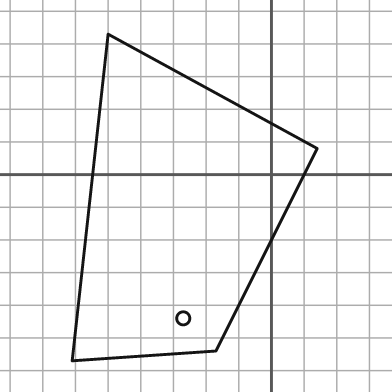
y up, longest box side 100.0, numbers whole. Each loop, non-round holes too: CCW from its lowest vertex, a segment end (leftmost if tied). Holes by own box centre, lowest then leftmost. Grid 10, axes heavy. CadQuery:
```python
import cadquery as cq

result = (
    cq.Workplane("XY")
    .moveTo(-61.0, -57.0)
    .lineTo(-17.0, -54.0)
    .lineTo(14.0, 8.0)
    .lineTo(-50.0, 43.0)
    .close()
    .moveTo(-27.0, -44.0)
    .circle(2.0)
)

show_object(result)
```